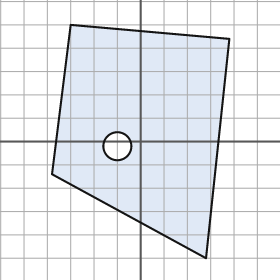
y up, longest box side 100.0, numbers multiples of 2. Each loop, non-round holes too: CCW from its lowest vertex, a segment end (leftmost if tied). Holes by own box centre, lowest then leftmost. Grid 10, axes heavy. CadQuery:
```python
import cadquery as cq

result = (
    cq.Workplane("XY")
    .moveTo(28.0, -50.0)
    .lineTo(38.0, 44.0)
    .lineTo(-30.0, 50.0)
    .lineTo(-38.0, -14.0)
    .close()
    .moveTo(-10.0, -2.0)
    .circle(6.0)
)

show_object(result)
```